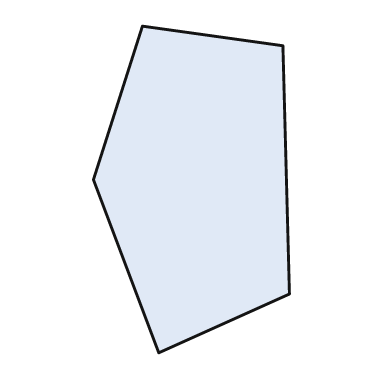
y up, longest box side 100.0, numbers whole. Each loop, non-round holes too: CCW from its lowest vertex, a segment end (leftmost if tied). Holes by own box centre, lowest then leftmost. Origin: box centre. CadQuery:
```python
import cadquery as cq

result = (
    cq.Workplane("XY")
    .moveTo(-10.0, -50.0)
    .lineTo(30.0, -32.0)
    .lineTo(28.0, 44.0)
    .lineTo(-15.0, 50.0)
    .lineTo(-30.0, 3.0)
    .close()
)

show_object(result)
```